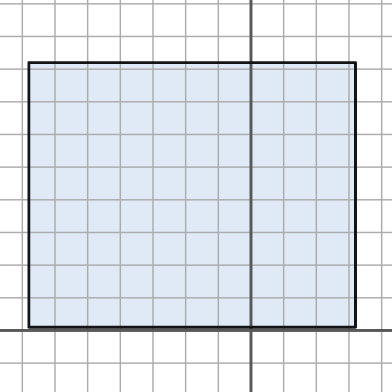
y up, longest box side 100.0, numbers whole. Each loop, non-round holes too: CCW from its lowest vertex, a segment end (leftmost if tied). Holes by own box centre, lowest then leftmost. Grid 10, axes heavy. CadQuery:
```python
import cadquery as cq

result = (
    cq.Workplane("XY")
    .moveTo(-68.0, 1.0)
    .lineTo(32.0, 1.0)
    .lineTo(32.0, 82.0)
    .lineTo(-68.0, 82.0)
    .close()
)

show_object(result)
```